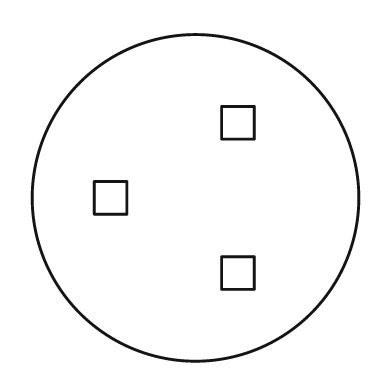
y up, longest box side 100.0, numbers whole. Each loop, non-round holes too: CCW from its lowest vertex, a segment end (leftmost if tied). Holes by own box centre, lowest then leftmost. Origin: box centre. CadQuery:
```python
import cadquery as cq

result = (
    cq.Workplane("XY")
    .moveTo(0.0, 0.0)
    .circle(50.0)
    .moveTo(8.0, -28.0)
    .lineTo(18.0, -28.0)
    .lineTo(18.0, -18.0)
    .lineTo(8.0, -18.0)
    .close()
    .moveTo(-31.0, -5.0)
    .lineTo(-21.0, -5.0)
    .lineTo(-21.0, 5.0)
    .lineTo(-31.0, 5.0)
    .close()
    .moveTo(8.0, 18.0)
    .lineTo(18.0, 18.0)
    .lineTo(18.0, 28.0)
    .lineTo(8.0, 28.0)
    .close()
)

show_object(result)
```